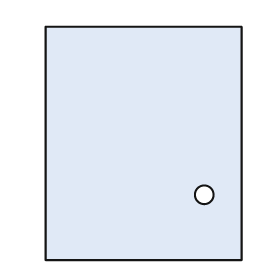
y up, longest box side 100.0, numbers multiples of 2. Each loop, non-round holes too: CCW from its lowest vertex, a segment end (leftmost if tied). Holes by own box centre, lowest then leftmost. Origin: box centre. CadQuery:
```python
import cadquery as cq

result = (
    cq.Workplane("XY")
    .moveTo(-42.0, -50.0)
    .lineTo(42.0, -50.0)
    .lineTo(42.0, 50.0)
    .lineTo(-42.0, 50.0)
    .close()
    .moveTo(26.0, -22.0)
    .circle(4.0)
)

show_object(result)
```